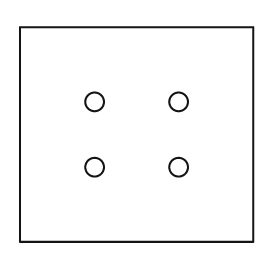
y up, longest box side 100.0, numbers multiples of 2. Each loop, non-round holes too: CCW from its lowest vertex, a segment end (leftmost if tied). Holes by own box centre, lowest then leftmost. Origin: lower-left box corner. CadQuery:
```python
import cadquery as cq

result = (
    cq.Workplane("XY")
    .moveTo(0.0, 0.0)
    .lineTo(100.0, 0.0)
    .lineTo(100.0, 92.0)
    .lineTo(0.0, 92.0)
    .close()
    .moveTo(32.0, 32.0)
    .circle(4.0)
    .moveTo(68.0, 32.0)
    .circle(4.0)
    .moveTo(32.0, 60.0)
    .circle(4.0)
    .moveTo(68.0, 60.0)
    .circle(4.0)
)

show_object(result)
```